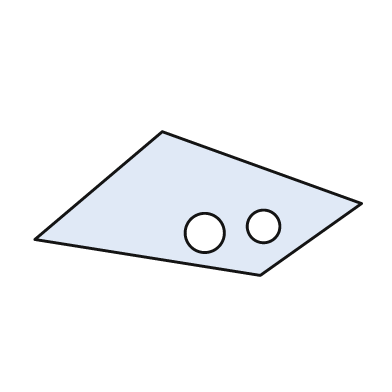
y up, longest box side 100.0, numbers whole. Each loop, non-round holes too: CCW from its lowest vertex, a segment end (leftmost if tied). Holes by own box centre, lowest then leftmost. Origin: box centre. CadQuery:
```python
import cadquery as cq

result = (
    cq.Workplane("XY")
    .moveTo(19.0, -22.0)
    .lineTo(50.0, 0.0)
    .lineTo(-11.0, 22.0)
    .lineTo(-50.0, -11.0)
    .close()
    .moveTo(2.0, -9.0)
    .circle(6.0)
    .moveTo(20.0, -7.0)
    .circle(5.0)
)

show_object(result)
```